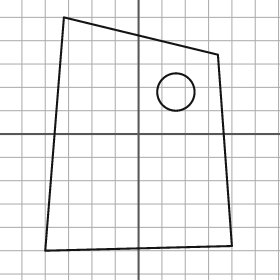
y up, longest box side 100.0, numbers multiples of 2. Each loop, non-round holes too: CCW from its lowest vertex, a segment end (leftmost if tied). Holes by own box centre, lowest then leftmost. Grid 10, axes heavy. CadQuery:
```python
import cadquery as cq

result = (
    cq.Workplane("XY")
    .moveTo(-40.0, -50.0)
    .lineTo(40.0, -48.0)
    .lineTo(34.0, 34.0)
    .lineTo(-32.0, 50.0)
    .close()
    .moveTo(16.0, 18.0)
    .circle(8.0)
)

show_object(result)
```